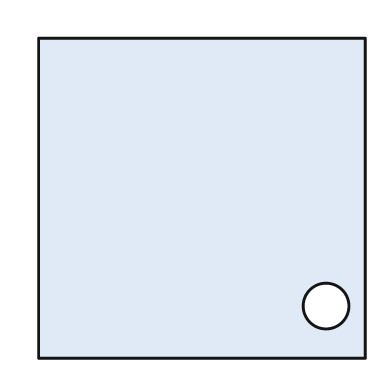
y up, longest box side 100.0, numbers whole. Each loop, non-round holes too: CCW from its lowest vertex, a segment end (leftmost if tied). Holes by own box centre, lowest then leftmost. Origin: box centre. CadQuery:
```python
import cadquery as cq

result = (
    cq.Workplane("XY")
    .moveTo(-50.0, -49.0)
    .lineTo(50.0, -49.0)
    .lineTo(50.0, 49.0)
    .lineTo(-50.0, 49.0)
    .close()
    .moveTo(38.0, -33.0)
    .circle(7.0)
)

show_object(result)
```